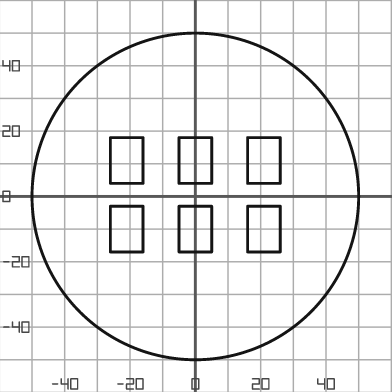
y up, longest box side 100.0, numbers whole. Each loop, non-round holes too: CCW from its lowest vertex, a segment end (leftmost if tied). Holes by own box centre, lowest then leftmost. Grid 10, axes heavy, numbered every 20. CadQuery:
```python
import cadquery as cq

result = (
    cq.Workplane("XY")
    .moveTo(0.0, 0.0)
    .circle(50.0)
    .moveTo(-26.0, -17.0)
    .lineTo(-16.0, -17.0)
    .lineTo(-16.0, -3.0)
    .lineTo(-26.0, -3.0)
    .close()
    .moveTo(-5.0, -17.0)
    .lineTo(5.0, -17.0)
    .lineTo(5.0, -3.0)
    .lineTo(-5.0, -3.0)
    .close()
    .moveTo(16.0, -17.0)
    .lineTo(26.0, -17.0)
    .lineTo(26.0, -3.0)
    .lineTo(16.0, -3.0)
    .close()
    .moveTo(-26.0, 4.0)
    .lineTo(-16.0, 4.0)
    .lineTo(-16.0, 18.0)
    .lineTo(-26.0, 18.0)
    .close()
    .moveTo(-5.0, 4.0)
    .lineTo(5.0, 4.0)
    .lineTo(5.0, 18.0)
    .lineTo(-5.0, 18.0)
    .close()
    .moveTo(16.0, 4.0)
    .lineTo(26.0, 4.0)
    .lineTo(26.0, 18.0)
    .lineTo(16.0, 18.0)
    .close()
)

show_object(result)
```